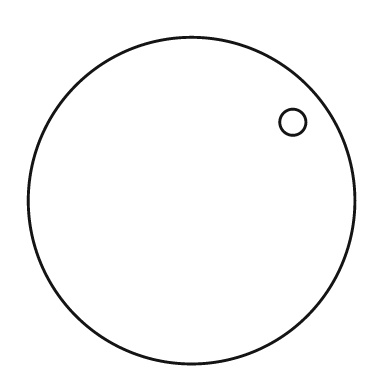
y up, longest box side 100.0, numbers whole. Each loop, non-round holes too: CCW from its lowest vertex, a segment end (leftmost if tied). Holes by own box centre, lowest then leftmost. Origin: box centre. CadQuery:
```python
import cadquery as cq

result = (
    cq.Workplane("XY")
    .moveTo(0.0, 0.0)
    .circle(50.0)
    .moveTo(31.0, 24.0)
    .circle(4.0)
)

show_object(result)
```